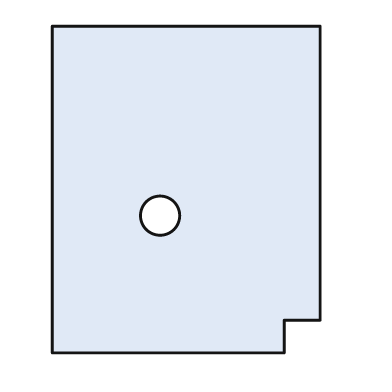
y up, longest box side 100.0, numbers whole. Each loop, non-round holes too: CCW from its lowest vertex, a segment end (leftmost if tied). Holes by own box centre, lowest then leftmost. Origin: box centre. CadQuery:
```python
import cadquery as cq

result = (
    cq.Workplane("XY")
    .moveTo(-41.0, -50.0)
    .lineTo(30.0, -50.0)
    .lineTo(30.0, -40.0)
    .lineTo(41.0, -40.0)
    .lineTo(41.0, 50.0)
    .lineTo(-41.0, 50.0)
    .close()
    .moveTo(-8.0, -8.0)
    .circle(6.0)
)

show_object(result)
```